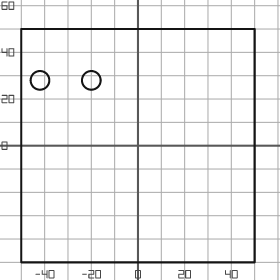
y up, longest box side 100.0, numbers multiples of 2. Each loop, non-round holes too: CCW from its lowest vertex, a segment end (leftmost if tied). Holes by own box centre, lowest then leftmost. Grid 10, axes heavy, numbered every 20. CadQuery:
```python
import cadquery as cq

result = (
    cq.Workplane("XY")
    .moveTo(-50.0, -50.0)
    .lineTo(50.0, -50.0)
    .lineTo(50.0, 50.0)
    .lineTo(-50.0, 50.0)
    .close()
    .moveTo(-42.0, 28.0)
    .circle(4.0)
    .moveTo(-20.0, 28.0)
    .circle(4.0)
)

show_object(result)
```